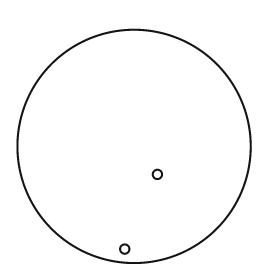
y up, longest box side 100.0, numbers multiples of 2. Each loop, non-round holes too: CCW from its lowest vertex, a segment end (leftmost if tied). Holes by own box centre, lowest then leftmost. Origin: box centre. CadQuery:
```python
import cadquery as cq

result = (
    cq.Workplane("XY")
    .moveTo(0.0, 0.0)
    .circle(50.0)
    .moveTo(-4.0, -44.0)
    .circle(2.0)
    .moveTo(10.0, -12.0)
    .circle(2.0)
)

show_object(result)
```